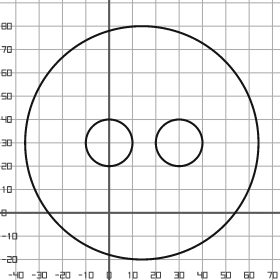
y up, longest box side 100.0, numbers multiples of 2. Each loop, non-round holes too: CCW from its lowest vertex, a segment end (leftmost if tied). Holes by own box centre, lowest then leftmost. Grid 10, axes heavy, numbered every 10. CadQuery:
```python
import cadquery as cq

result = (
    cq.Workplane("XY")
    .moveTo(14.0, 30.0)
    .circle(50.0)
    .moveTo(0.0, 30.0)
    .circle(10.0)
    .moveTo(30.0, 30.0)
    .circle(10.0)
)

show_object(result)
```